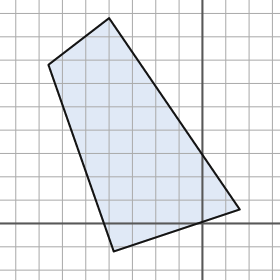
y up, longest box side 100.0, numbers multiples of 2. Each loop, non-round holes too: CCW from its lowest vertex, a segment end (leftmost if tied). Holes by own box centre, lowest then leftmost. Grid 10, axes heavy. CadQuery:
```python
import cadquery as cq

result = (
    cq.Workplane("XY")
    .moveTo(-38.0, -12.0)
    .lineTo(16.0, 6.0)
    .lineTo(-40.0, 88.0)
    .lineTo(-66.0, 68.0)
    .close()
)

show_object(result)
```